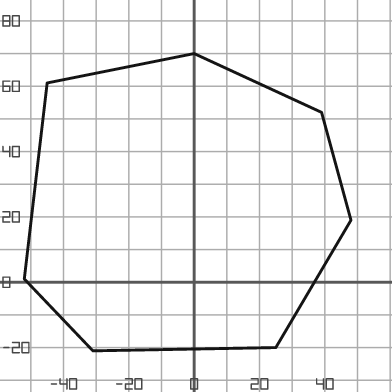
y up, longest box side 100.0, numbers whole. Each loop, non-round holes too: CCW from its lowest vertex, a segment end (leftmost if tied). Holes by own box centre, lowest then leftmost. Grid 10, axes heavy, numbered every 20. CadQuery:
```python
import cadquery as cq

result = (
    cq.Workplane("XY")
    .moveTo(-31.0, -21.0)
    .lineTo(25.0, -20.0)
    .lineTo(48.0, 19.0)
    .lineTo(39.0, 52.0)
    .lineTo(0.0, 70.0)
    .lineTo(-45.0, 61.0)
    .lineTo(-52.0, 1.0)
    .close()
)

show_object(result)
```